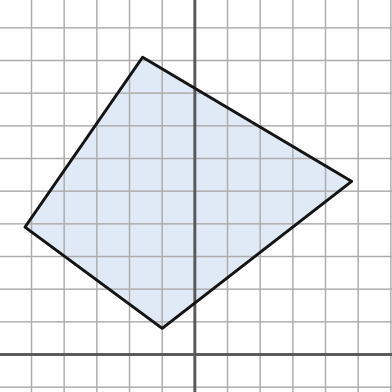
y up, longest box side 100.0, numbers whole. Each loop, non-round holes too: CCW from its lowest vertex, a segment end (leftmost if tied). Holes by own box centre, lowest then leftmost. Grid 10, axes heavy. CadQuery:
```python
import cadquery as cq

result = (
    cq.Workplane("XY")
    .moveTo(-10.0, 8.0)
    .lineTo(48.0, 53.0)
    .lineTo(-16.0, 91.0)
    .lineTo(-52.0, 39.0)
    .close()
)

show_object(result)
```